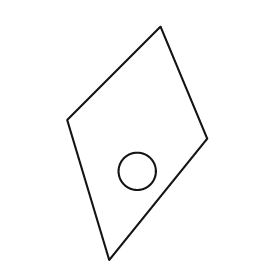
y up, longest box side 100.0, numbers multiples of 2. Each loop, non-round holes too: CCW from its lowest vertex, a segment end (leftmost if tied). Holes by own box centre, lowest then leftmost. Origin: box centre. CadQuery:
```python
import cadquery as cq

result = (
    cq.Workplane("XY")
    .moveTo(-12.0, -50.0)
    .lineTo(30.0, 2.0)
    .lineTo(10.0, 50.0)
    .lineTo(-30.0, 10.0)
    .close()
    .moveTo(0.0, -12.0)
    .circle(8.0)
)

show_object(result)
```